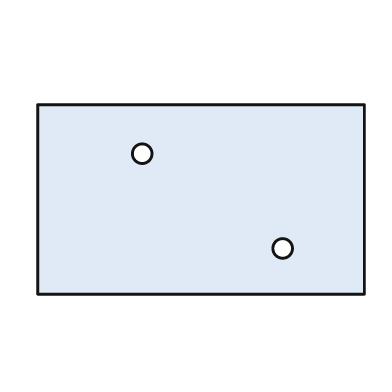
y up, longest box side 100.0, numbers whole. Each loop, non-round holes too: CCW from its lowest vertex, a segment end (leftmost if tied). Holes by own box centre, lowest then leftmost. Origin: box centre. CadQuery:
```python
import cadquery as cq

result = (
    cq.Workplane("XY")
    .moveTo(-50.0, -29.0)
    .lineTo(50.0, -29.0)
    .lineTo(50.0, 29.0)
    .lineTo(-50.0, 29.0)
    .close()
    .moveTo(25.0, -15.0)
    .circle(3.0)
    .moveTo(-18.0, 14.0)
    .circle(3.0)
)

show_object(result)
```